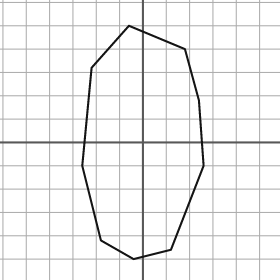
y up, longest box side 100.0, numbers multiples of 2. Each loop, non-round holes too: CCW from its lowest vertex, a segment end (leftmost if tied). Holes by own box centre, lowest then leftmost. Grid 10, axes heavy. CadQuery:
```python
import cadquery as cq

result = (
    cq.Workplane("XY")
    .moveTo(-4.0, -50.0)
    .lineTo(12.0, -46.0)
    .lineTo(26.0, -10.0)
    .lineTo(24.0, 18.0)
    .lineTo(18.0, 40.0)
    .lineTo(-6.0, 50.0)
    .lineTo(-22.0, 32.0)
    .lineTo(-26.0, -10.0)
    .lineTo(-18.0, -42.0)
    .close()
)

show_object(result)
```